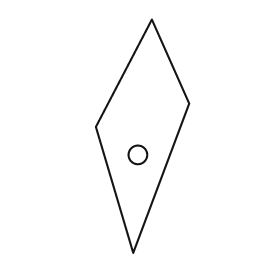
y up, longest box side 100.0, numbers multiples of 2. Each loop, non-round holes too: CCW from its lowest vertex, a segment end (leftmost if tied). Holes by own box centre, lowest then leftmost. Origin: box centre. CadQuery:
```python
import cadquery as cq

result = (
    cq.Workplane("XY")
    .moveTo(-4.0, -50.0)
    .lineTo(20.0, 14.0)
    .lineTo(4.0, 50.0)
    .lineTo(-20.0, 4.0)
    .close()
    .moveTo(-2.0, -8.0)
    .circle(4.0)
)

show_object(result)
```